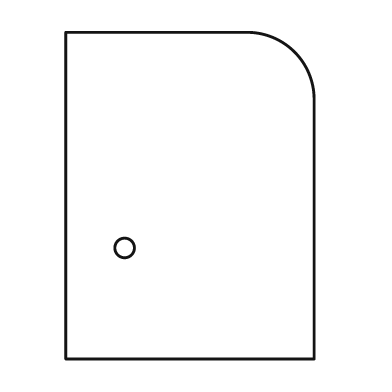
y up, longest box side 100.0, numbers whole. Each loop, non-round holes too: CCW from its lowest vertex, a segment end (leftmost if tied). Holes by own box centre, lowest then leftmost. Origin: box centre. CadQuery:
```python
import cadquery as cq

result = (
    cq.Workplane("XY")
    .moveTo(-38.0, -50.0)
    .lineTo(38.0, -50.0)
    .lineTo(38.0, 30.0)
    .threePointArc((32.0, 44.0), (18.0, 50.0))
    .lineTo(-38.0, 50.0)
    .close()
    .moveTo(-20.0, -16.0)
    .circle(3.0)
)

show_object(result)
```